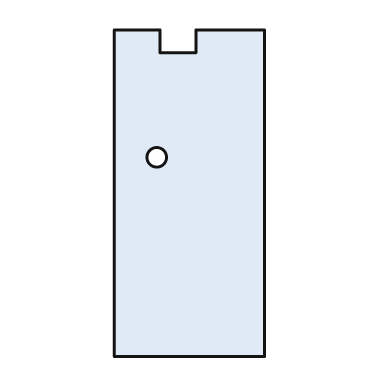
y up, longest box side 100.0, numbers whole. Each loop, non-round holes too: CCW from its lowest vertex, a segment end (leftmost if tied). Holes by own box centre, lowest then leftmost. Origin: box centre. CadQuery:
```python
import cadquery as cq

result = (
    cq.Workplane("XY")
    .moveTo(-23.0, -50.0)
    .lineTo(23.0, -50.0)
    .lineTo(23.0, 50.0)
    .lineTo(2.0, 50.0)
    .lineTo(2.0, 43.0)
    .lineTo(-9.0, 43.0)
    .lineTo(-9.0, 50.0)
    .lineTo(-23.0, 50.0)
    .close()
    .moveTo(-10.0, 11.0)
    .circle(3.0)
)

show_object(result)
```